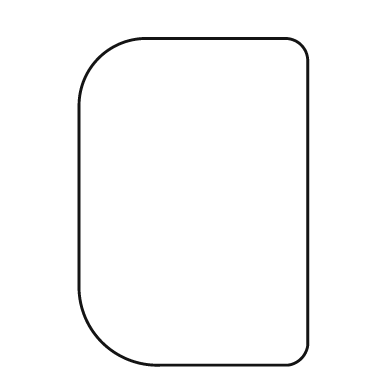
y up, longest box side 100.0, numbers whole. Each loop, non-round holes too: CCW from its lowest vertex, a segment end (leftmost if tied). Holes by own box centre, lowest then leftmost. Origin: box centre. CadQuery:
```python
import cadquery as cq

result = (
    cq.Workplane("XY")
    .moveTo(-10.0, -50.0)
    .lineTo(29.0, -50.0)
    .threePointArc((33.0, -48.0), (35.0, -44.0))
    .lineTo(35.0, 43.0)
    .threePointArc((33.0, 48.0), (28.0, 50.0))
    .lineTo(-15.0, 50.0)
    .threePointArc((-29.0, 44.0), (-35.0, 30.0))
    .lineTo(-35.0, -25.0)
    .threePointArc((-28.0, -43.0), (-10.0, -50.0))
    .close()
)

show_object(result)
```